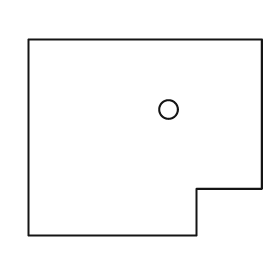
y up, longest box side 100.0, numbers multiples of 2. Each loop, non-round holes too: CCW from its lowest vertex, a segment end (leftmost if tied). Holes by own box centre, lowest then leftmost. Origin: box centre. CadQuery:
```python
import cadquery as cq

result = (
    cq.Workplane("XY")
    .moveTo(-50.0, -42.0)
    .lineTo(22.0, -42.0)
    .lineTo(22.0, -22.0)
    .lineTo(50.0, -22.0)
    .lineTo(50.0, 42.0)
    .lineTo(-50.0, 42.0)
    .close()
    .moveTo(10.0, 12.0)
    .circle(4.0)
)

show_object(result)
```